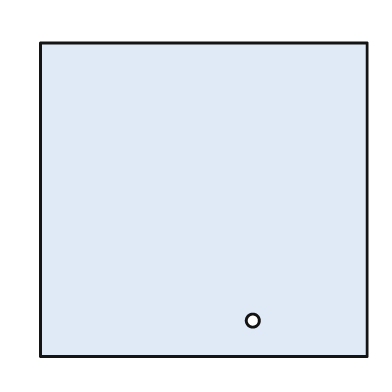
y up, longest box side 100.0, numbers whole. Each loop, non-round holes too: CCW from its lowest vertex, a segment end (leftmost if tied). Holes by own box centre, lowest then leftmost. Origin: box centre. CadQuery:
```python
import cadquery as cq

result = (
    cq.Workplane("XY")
    .moveTo(-50.0, -48.0)
    .lineTo(50.0, -48.0)
    .lineTo(50.0, 48.0)
    .lineTo(-50.0, 48.0)
    .close()
    .moveTo(15.0, -37.0)
    .circle(2.0)
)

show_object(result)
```